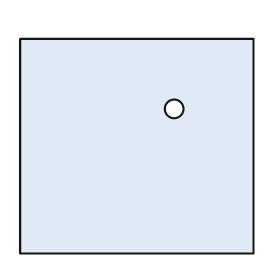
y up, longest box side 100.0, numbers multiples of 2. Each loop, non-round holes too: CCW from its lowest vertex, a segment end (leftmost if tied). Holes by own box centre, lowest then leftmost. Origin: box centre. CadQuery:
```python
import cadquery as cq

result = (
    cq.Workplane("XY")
    .moveTo(-50.0, -46.0)
    .lineTo(50.0, -46.0)
    .lineTo(50.0, 46.0)
    .lineTo(-50.0, 46.0)
    .close()
    .moveTo(16.0, 16.0)
    .circle(4.0)
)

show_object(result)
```